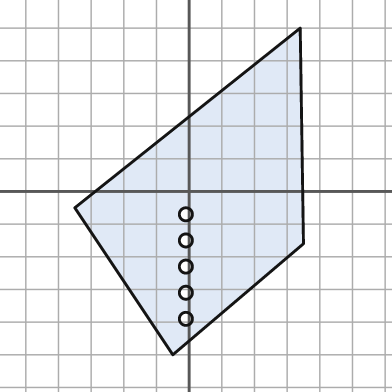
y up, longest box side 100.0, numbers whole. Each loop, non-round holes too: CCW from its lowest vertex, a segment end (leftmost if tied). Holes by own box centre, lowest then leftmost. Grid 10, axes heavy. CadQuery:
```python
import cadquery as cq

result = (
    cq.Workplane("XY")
    .moveTo(-5.0, -50.0)
    .lineTo(35.0, -16.0)
    .lineTo(34.0, 50.0)
    .lineTo(-35.0, -5.0)
    .close()
    .moveTo(-1.0, -39.0)
    .circle(2.0)
    .moveTo(-1.0, -31.0)
    .circle(2.0)
    .moveTo(-1.0, -23.0)
    .circle(2.0)
    .moveTo(-1.0, -15.0)
    .circle(2.0)
    .moveTo(-1.0, -7.0)
    .circle(2.0)
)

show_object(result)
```